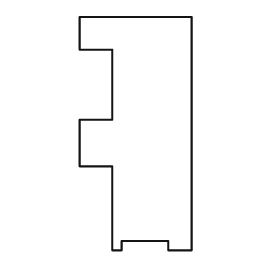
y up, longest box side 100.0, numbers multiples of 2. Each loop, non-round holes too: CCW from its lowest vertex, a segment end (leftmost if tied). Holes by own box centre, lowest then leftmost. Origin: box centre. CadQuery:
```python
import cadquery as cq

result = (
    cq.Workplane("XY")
    .moveTo(-10.0, -50.0)
    .lineTo(-6.0, -50.0)
    .lineTo(-6.0, -46.0)
    .lineTo(14.0, -46.0)
    .lineTo(14.0, -50.0)
    .lineTo(24.0, -50.0)
    .lineTo(24.0, 50.0)
    .lineTo(-24.0, 50.0)
    .lineTo(-24.0, 36.0)
    .lineTo(-10.0, 36.0)
    .lineTo(-10.0, 6.0)
    .lineTo(-24.0, 6.0)
    .lineTo(-24.0, -14.0)
    .lineTo(-10.0, -14.0)
    .close()
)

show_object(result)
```